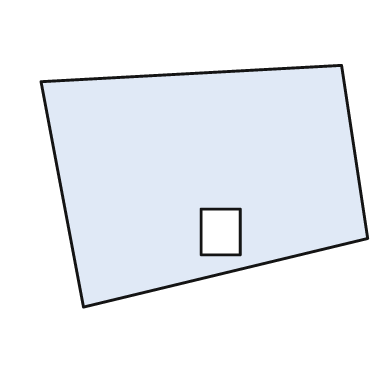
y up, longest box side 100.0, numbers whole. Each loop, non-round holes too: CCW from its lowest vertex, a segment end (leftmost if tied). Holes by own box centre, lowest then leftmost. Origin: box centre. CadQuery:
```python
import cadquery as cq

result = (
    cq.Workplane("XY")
    .moveTo(-37.0, -37.0)
    .lineTo(50.0, -16.0)
    .lineTo(42.0, 37.0)
    .lineTo(-50.0, 32.0)
    .close()
    .moveTo(-1.0, -21.0)
    .lineTo(11.0, -21.0)
    .lineTo(11.0, -7.0)
    .lineTo(-1.0, -7.0)
    .close()
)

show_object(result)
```